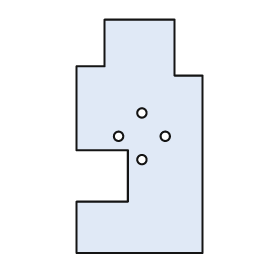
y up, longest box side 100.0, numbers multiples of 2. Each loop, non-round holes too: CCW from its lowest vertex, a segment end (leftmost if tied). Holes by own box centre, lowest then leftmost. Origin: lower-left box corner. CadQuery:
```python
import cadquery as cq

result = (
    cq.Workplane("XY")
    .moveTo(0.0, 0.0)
    .lineTo(54.0, 0.0)
    .lineTo(54.0, 76.0)
    .lineTo(42.0, 76.0)
    .lineTo(42.0, 100.0)
    .lineTo(12.0, 100.0)
    .lineTo(12.0, 80.0)
    .lineTo(0.0, 80.0)
    .lineTo(0.0, 44.0)
    .lineTo(22.0, 44.0)
    .lineTo(22.0, 22.0)
    .lineTo(0.0, 22.0)
    .close()
    .moveTo(28.0, 40.0)
    .circle(2.0)
    .moveTo(18.0, 50.0)
    .circle(2.0)
    .moveTo(38.0, 50.0)
    .circle(2.0)
    .moveTo(28.0, 60.0)
    .circle(2.0)
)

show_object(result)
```